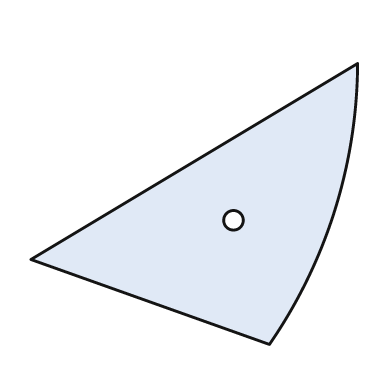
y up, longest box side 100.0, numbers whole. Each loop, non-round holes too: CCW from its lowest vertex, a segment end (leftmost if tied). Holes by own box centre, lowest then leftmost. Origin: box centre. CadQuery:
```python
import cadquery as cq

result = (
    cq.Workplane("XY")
    .moveTo(23.0, -43.0)
    .threePointArc((43.0, -2.0), (50.0, 43.0))
    .lineTo(-50.0, -17.0)
    .close()
    .moveTo(12.0, -5.0)
    .circle(3.0)
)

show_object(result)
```